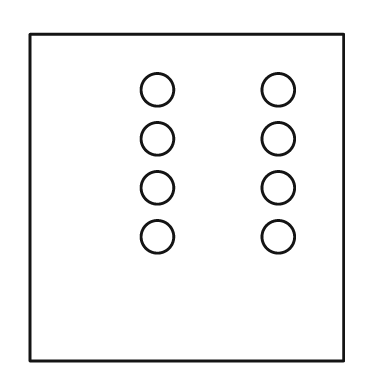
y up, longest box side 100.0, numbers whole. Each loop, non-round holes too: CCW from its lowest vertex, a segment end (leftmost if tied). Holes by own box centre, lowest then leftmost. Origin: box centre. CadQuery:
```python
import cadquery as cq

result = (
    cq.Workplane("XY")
    .moveTo(-48.0, -50.0)
    .lineTo(48.0, -50.0)
    .lineTo(48.0, 50.0)
    .lineTo(-48.0, 50.0)
    .close()
    .moveTo(-9.0, -12.0)
    .circle(5.0)
    .moveTo(28.0, -12.0)
    .circle(5.0)
    .moveTo(-9.0, 3.0)
    .circle(5.0)
    .moveTo(28.0, 3.0)
    .circle(5.0)
    .moveTo(-9.0, 18.0)
    .circle(5.0)
    .moveTo(28.0, 18.0)
    .circle(5.0)
    .moveTo(-9.0, 33.0)
    .circle(5.0)
    .moveTo(28.0, 33.0)
    .circle(5.0)
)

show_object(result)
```